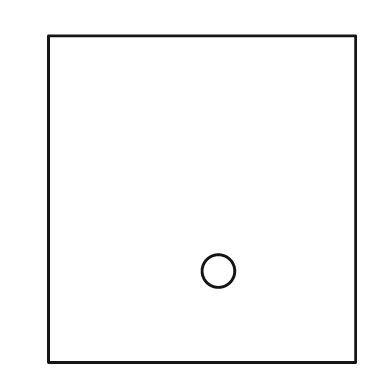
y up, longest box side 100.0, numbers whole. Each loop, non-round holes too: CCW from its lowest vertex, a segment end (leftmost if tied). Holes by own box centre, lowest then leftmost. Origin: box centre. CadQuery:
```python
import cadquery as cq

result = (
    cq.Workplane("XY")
    .moveTo(-47.0, -50.0)
    .lineTo(47.0, -50.0)
    .lineTo(47.0, 50.0)
    .lineTo(-47.0, 50.0)
    .close()
    .moveTo(5.0, -22.0)
    .circle(5.0)
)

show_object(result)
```